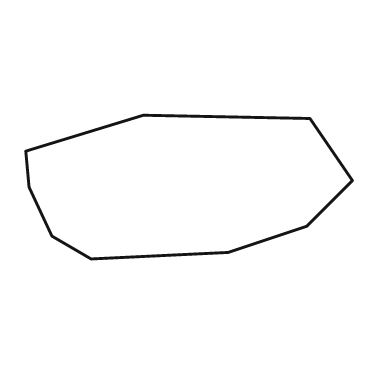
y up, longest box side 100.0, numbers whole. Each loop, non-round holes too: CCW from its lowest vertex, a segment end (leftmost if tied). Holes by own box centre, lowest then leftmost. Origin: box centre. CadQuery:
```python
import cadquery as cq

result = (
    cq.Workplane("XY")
    .moveTo(-30.0, -22.0)
    .lineTo(12.0, -20.0)
    .lineTo(36.0, -12.0)
    .lineTo(50.0, 2.0)
    .lineTo(37.0, 21.0)
    .lineTo(-14.0, 22.0)
    .lineTo(-50.0, 11.0)
    .lineTo(-49.0, 0.0)
    .lineTo(-42.0, -15.0)
    .close()
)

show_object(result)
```